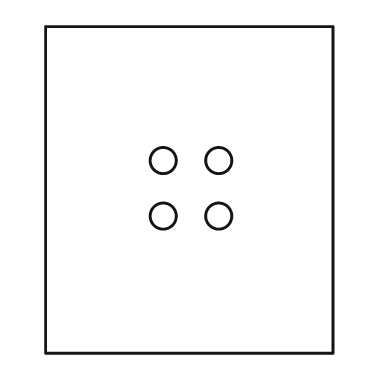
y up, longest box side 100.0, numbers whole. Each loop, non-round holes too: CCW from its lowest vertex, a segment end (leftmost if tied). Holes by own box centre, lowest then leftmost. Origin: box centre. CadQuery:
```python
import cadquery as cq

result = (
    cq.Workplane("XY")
    .moveTo(-44.0, -50.0)
    .lineTo(44.0, -50.0)
    .lineTo(44.0, 50.0)
    .lineTo(-44.0, 50.0)
    .close()
    .moveTo(-8.0, -8.0)
    .circle(4.0)
    .moveTo(9.0, -8.0)
    .circle(4.0)
    .moveTo(-8.0, 9.0)
    .circle(4.0)
    .moveTo(9.0, 9.0)
    .circle(4.0)
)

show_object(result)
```